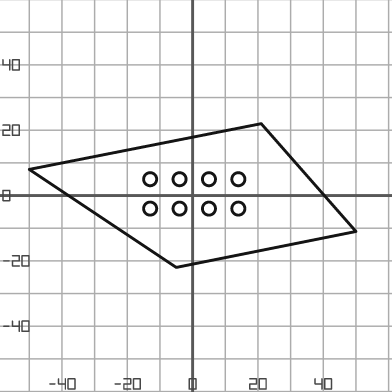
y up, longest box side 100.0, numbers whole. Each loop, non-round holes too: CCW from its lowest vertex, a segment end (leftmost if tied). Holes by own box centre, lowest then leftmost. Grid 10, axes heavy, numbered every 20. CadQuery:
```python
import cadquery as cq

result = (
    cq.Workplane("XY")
    .moveTo(-5.0, -22.0)
    .lineTo(50.0, -11.0)
    .lineTo(21.0, 22.0)
    .lineTo(-50.0, 8.0)
    .close()
    .moveTo(-13.0, -4.0)
    .circle(2.0)
    .moveTo(-4.0, -4.0)
    .circle(2.0)
    .moveTo(5.0, -4.0)
    .circle(2.0)
    .moveTo(14.0, -4.0)
    .circle(2.0)
    .moveTo(-13.0, 5.0)
    .circle(2.0)
    .moveTo(-4.0, 5.0)
    .circle(2.0)
    .moveTo(5.0, 5.0)
    .circle(2.0)
    .moveTo(14.0, 5.0)
    .circle(2.0)
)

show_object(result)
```